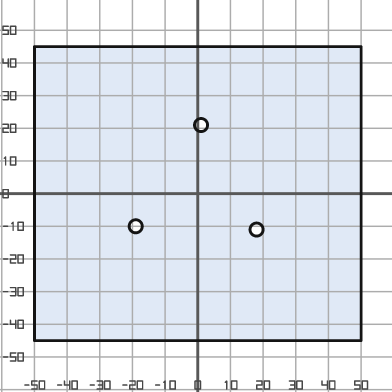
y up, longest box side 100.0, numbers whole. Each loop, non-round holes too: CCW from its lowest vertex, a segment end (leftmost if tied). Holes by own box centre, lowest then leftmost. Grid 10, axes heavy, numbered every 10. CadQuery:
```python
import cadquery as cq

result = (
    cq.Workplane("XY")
    .moveTo(-50.0, -45.0)
    .lineTo(50.0, -45.0)
    .lineTo(50.0, 45.0)
    .lineTo(-50.0, 45.0)
    .close()
    .moveTo(18.0, -11.0)
    .circle(2.0)
    .moveTo(-19.0, -10.0)
    .circle(2.0)
    .moveTo(1.0, 21.0)
    .circle(2.0)
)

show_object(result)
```